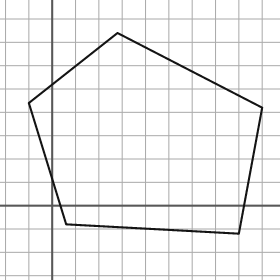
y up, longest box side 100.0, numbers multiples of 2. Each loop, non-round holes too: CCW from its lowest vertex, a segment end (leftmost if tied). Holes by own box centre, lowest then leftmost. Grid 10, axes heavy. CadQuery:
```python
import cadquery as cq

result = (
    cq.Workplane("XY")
    .moveTo(80.0, -12.0)
    .lineTo(90.0, 42.0)
    .lineTo(28.0, 74.0)
    .lineTo(-10.0, 44.0)
    .lineTo(6.0, -8.0)
    .close()
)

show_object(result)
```